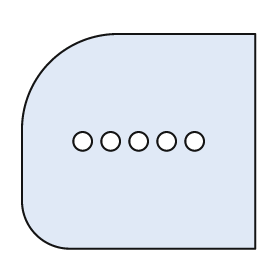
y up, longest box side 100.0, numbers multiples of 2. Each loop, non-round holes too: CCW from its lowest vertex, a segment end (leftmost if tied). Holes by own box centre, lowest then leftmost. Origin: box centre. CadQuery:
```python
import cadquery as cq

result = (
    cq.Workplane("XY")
    .moveTo(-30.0, -46.0)
    .lineTo(50.0, -46.0)
    .lineTo(50.0, 46.0)
    .lineTo(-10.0, 46.0)
    .threePointArc((-38.0, 34.0), (-50.0, 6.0))
    .lineTo(-50.0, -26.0)
    .threePointArc((-44.0, -40.0), (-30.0, -46.0))
    .close()
    .moveTo(-24.0, 0.0)
    .circle(4.0)
    .moveTo(-12.0, 0.0)
    .circle(4.0)
    .moveTo(0.0, 0.0)
    .circle(4.0)
    .moveTo(12.0, 0.0)
    .circle(4.0)
    .moveTo(24.0, 0.0)
    .circle(4.0)
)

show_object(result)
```